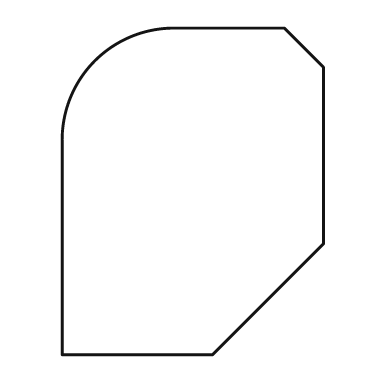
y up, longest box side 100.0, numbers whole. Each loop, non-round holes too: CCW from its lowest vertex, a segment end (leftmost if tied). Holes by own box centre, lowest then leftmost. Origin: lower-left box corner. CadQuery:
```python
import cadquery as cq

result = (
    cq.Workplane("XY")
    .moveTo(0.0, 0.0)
    .lineTo(46.0, 0.0)
    .lineTo(80.0, 34.0)
    .lineTo(80.0, 88.0)
    .lineTo(68.0, 100.0)
    .lineTo(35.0, 100.0)
    .threePointArc((10.0, 90.0), (0.0, 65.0))
    .close()
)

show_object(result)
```